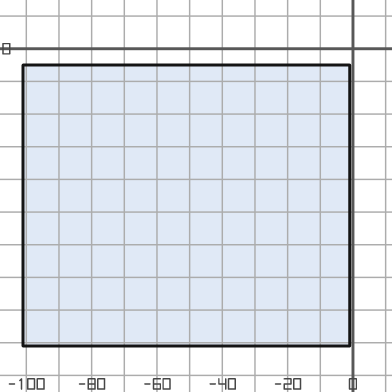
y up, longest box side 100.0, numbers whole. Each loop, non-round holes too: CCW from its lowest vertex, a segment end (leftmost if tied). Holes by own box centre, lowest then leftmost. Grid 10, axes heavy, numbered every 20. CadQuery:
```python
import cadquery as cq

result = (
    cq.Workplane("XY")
    .moveTo(-101.0, -91.0)
    .lineTo(-1.0, -91.0)
    .lineTo(-1.0, -5.0)
    .lineTo(-101.0, -5.0)
    .close()
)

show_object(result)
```